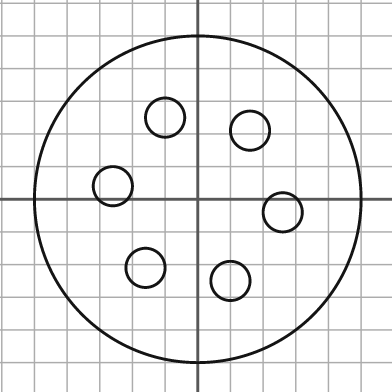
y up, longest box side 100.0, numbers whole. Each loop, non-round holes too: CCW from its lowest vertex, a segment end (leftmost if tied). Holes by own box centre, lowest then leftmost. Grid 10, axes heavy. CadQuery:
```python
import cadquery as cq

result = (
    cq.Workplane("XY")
    .moveTo(0.0, 0.0)
    .circle(50.0)
    .moveTo(10.0, -25.0)
    .circle(6.0)
    .moveTo(-16.0, -21.0)
    .circle(6.0)
    .moveTo(26.0, -4.0)
    .circle(6.0)
    .moveTo(-26.0, 4.0)
    .circle(6.0)
    .moveTo(16.0, 21.0)
    .circle(6.0)
    .moveTo(-10.0, 25.0)
    .circle(6.0)
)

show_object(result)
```